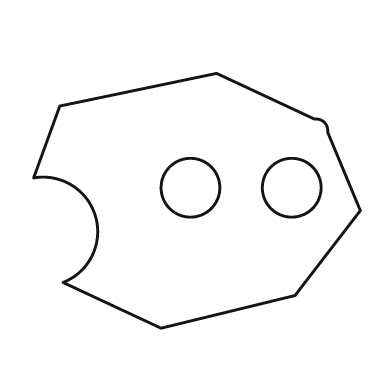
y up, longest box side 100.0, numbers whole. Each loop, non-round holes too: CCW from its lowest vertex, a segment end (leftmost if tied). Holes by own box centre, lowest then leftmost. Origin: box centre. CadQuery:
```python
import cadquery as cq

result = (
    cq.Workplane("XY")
    .moveTo(-11.0, -39.0)
    .lineTo(30.0, -29.0)
    .lineTo(50.0, -3.0)
    .lineTo(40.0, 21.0)
    .threePointArc((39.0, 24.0), (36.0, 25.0))
    .lineTo(6.0, 39.0)
    .lineTo(-42.0, 29.0)
    .lineTo(-50.0, 7.0)
    .threePointArc((-31.0, -5.0), (-41.0, -25.0))
    .close()
    .moveTo(-2.0, 4.0)
    .circle(9.0)
    .moveTo(29.0, 4.0)
    .circle(9.0)
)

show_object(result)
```